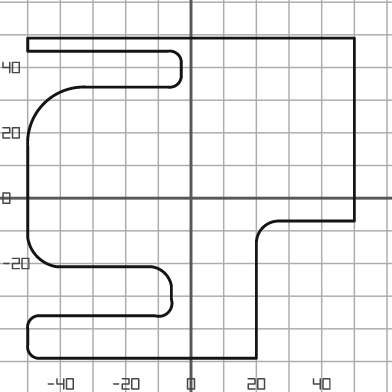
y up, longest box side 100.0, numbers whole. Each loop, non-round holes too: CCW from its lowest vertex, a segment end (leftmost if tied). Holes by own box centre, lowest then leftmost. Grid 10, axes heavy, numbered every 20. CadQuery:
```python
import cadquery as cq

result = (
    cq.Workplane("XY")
    .moveTo(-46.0, -49.0)
    .lineTo(20.0, -49.0)
    .lineTo(20.0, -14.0)
    .threePointArc((22.0, -9.0), (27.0, -7.0))
    .lineTo(50.0, -7.0)
    .lineTo(50.0, 49.0)
    .lineTo(-50.0, 49.0)
    .lineTo(-50.0, 45.0)
    .lineTo(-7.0, 45.0)
    .threePointArc((-4.0, 44.0), (-3.0, 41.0))
    .lineTo(-3.0, 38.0)
    .threePointArc((-4.0, 35.0), (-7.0, 34.0))
    .lineTo(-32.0, 34.0)
    .threePointArc((-45.0, 29.0), (-50.0, 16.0))
    .lineTo(-50.0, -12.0)
    .threePointArc((-47.0, -18.0), (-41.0, -21.0))
    .lineTo(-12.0, -21.0)
    .threePointArc((-8.0, -23.0), (-6.0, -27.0))
    .lineTo(-6.0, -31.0)
    .threePointArc((-7.0, -35.0), (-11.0, -36.0))
    .lineTo(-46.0, -36.0)
    .threePointArc((-49.0, -37.0), (-50.0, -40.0))
    .lineTo(-50.0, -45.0)
    .threePointArc((-49.0, -48.0), (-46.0, -49.0))
    .close()
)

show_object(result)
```